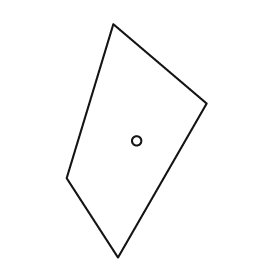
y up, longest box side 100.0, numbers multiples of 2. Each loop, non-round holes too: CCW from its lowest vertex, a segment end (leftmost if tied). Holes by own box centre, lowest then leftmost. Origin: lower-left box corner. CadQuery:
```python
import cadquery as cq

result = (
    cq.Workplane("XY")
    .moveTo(22.0, 0.0)
    .lineTo(60.0, 66.0)
    .lineTo(20.0, 100.0)
    .lineTo(0.0, 34.0)
    .close()
    .moveTo(30.0, 50.0)
    .circle(2.0)
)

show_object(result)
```